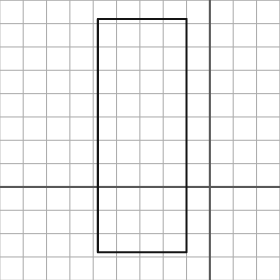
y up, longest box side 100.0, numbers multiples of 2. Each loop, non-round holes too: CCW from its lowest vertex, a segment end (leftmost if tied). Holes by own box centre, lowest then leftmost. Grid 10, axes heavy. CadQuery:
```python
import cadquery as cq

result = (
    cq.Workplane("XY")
    .moveTo(-48.0, -28.0)
    .lineTo(-10.0, -28.0)
    .lineTo(-10.0, 72.0)
    .lineTo(-48.0, 72.0)
    .close()
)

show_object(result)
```